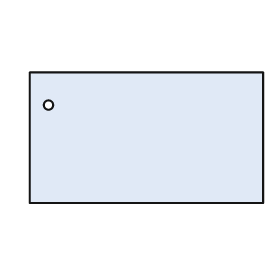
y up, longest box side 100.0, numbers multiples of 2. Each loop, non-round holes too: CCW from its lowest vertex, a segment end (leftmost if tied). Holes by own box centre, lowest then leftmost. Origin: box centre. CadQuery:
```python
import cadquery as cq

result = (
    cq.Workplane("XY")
    .moveTo(-50.0, -28.0)
    .lineTo(50.0, -28.0)
    .lineTo(50.0, 28.0)
    .lineTo(-50.0, 28.0)
    .close()
    .moveTo(-42.0, 14.0)
    .circle(2.0)
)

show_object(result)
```